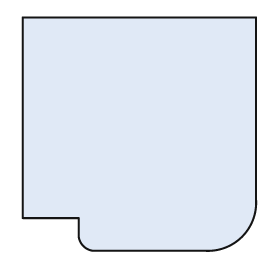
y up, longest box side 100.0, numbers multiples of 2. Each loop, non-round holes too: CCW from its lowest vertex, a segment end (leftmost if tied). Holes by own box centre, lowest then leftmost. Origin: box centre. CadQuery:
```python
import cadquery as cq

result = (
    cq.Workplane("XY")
    .moveTo(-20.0, -50.0)
    .lineTo(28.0, -50.0)
    .threePointArc((44.0, -44.0), (50.0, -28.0))
    .lineTo(50.0, 50.0)
    .lineTo(-50.0, 50.0)
    .lineTo(-50.0, -36.0)
    .lineTo(-26.0, -36.0)
    .lineTo(-26.0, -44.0)
    .threePointArc((-24.0, -48.0), (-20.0, -50.0))
    .close()
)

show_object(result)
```